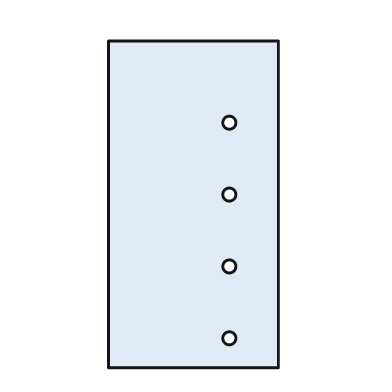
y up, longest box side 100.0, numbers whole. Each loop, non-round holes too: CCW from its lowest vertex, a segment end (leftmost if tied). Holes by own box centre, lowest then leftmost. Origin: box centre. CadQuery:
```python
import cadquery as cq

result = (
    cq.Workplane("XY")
    .moveTo(-26.0, -50.0)
    .lineTo(26.0, -50.0)
    .lineTo(26.0, 50.0)
    .lineTo(-26.0, 50.0)
    .close()
    .moveTo(11.0, -41.0)
    .circle(2.0)
    .moveTo(11.0, -19.0)
    .circle(2.0)
    .moveTo(11.0, 3.0)
    .circle(2.0)
    .moveTo(11.0, 25.0)
    .circle(2.0)
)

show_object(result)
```